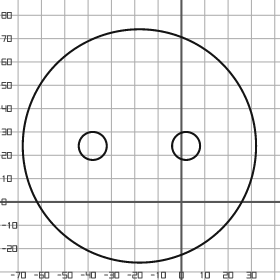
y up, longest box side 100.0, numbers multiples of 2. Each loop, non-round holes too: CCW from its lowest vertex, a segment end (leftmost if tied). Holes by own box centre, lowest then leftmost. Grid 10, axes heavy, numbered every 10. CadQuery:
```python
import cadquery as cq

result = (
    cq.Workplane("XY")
    .moveTo(-18.0, 24.0)
    .circle(50.0)
    .moveTo(-38.0, 24.0)
    .circle(6.0)
    .moveTo(2.0, 24.0)
    .circle(6.0)
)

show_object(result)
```